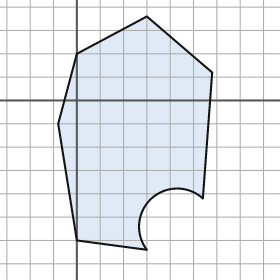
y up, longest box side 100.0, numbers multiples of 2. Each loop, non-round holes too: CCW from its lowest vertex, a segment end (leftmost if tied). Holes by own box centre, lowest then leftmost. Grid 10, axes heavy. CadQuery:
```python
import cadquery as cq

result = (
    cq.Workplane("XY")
    .moveTo(30.0, -64.0)
    .threePointArc((32.0, -42.0), (54.0, -42.0))
    .lineTo(58.0, 12.0)
    .lineTo(30.0, 36.0)
    .lineTo(0.0, 20.0)
    .lineTo(-8.0, -10.0)
    .lineTo(0.0, -60.0)
    .close()
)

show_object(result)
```